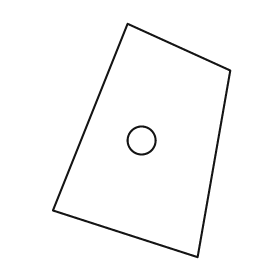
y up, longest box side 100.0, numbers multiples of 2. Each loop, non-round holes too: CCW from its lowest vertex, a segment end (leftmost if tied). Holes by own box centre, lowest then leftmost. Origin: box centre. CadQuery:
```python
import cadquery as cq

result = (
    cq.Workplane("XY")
    .moveTo(24.0, -50.0)
    .lineTo(38.0, 30.0)
    .lineTo(-6.0, 50.0)
    .lineTo(-38.0, -30.0)
    .close()
    .moveTo(0.0, 0.0)
    .circle(6.0)
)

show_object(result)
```